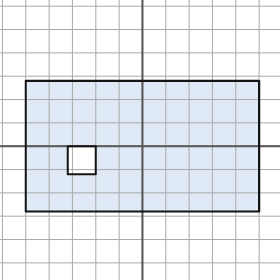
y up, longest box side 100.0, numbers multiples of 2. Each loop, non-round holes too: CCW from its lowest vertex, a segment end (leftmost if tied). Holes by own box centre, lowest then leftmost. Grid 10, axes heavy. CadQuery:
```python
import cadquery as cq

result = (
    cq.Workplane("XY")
    .moveTo(-50.0, -28.0)
    .lineTo(50.0, -28.0)
    .lineTo(50.0, 28.0)
    .lineTo(-50.0, 28.0)
    .close()
    .moveTo(-32.0, -12.0)
    .lineTo(-20.0, -12.0)
    .lineTo(-20.0, 0.0)
    .lineTo(-32.0, 0.0)
    .close()
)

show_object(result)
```